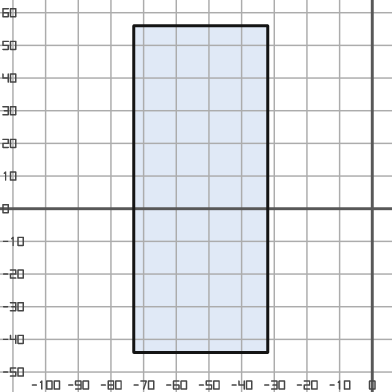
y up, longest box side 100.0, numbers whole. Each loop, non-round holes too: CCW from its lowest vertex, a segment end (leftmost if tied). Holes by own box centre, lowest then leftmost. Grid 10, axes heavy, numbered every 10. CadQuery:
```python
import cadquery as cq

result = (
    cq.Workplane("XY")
    .moveTo(-73.0, -44.0)
    .lineTo(-32.0, -44.0)
    .lineTo(-32.0, 56.0)
    .lineTo(-73.0, 56.0)
    .close()
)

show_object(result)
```